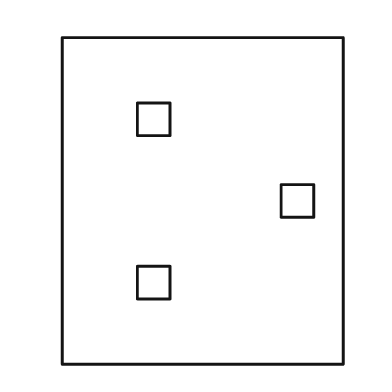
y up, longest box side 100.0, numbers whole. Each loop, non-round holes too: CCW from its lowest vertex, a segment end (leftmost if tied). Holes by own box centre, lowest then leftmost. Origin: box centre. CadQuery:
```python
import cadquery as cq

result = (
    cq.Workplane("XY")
    .moveTo(-43.0, -50.0)
    .lineTo(43.0, -50.0)
    .lineTo(43.0, 50.0)
    .lineTo(-43.0, 50.0)
    .close()
    .moveTo(-20.0, -30.0)
    .lineTo(-10.0, -30.0)
    .lineTo(-10.0, -20.0)
    .lineTo(-20.0, -20.0)
    .close()
    .moveTo(24.0, -5.0)
    .lineTo(34.0, -5.0)
    .lineTo(34.0, 5.0)
    .lineTo(24.0, 5.0)
    .close()
    .moveTo(-20.0, 20.0)
    .lineTo(-10.0, 20.0)
    .lineTo(-10.0, 30.0)
    .lineTo(-20.0, 30.0)
    .close()
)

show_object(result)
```